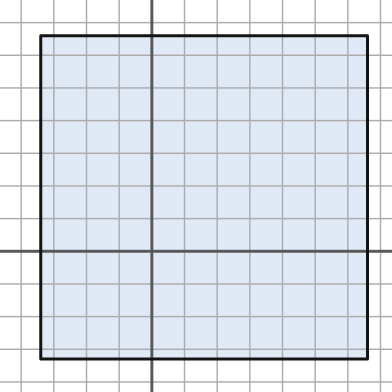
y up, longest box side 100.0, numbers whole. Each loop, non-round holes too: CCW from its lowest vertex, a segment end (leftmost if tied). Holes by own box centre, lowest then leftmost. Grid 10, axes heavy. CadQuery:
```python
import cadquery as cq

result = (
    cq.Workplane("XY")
    .moveTo(-34.0, -33.0)
    .lineTo(66.0, -33.0)
    .lineTo(66.0, 66.0)
    .lineTo(-34.0, 66.0)
    .close()
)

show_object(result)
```